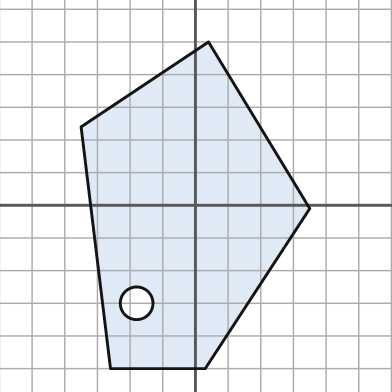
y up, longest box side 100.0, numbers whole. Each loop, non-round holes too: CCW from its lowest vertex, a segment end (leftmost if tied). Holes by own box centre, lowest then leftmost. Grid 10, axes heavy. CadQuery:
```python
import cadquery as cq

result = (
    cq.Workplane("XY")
    .moveTo(-26.0, -50.0)
    .lineTo(3.0, -50.0)
    .lineTo(35.0, -1.0)
    .lineTo(4.0, 50.0)
    .lineTo(-35.0, 24.0)
    .close()
    .moveTo(-18.0, -30.0)
    .circle(5.0)
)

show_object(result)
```